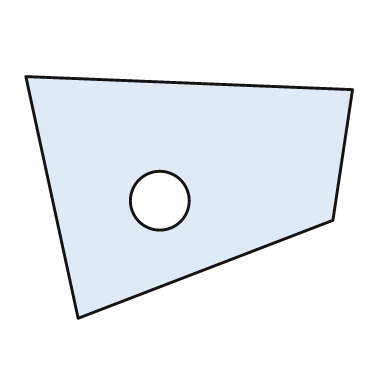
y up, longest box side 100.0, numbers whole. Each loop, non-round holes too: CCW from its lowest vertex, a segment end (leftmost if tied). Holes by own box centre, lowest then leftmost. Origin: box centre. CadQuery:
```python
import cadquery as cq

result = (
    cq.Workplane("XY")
    .moveTo(-34.0, -37.0)
    .lineTo(44.0, -7.0)
    .lineTo(50.0, 33.0)
    .lineTo(-50.0, 37.0)
    .close()
    .moveTo(-9.0, -1.0)
    .circle(9.0)
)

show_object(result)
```